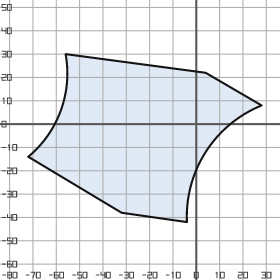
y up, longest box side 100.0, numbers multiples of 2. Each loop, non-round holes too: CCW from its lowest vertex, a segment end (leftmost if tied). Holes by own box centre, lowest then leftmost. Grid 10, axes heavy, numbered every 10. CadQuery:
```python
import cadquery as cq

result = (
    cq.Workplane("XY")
    .moveTo(-4.0, -42.0)
    .threePointArc((4.0, -12.0), (28.0, 8.0))
    .lineTo(4.0, 22.0)
    .lineTo(-56.0, 30.0)
    .threePointArc((-58.0, 6.0), (-72.0, -14.0))
    .lineTo(-32.0, -38.0)
    .close()
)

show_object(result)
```